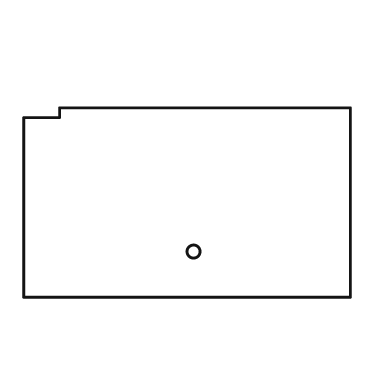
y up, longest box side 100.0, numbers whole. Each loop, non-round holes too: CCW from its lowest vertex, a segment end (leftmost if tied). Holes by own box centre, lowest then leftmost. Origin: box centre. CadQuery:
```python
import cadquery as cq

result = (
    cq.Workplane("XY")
    .moveTo(-50.0, -29.0)
    .lineTo(50.0, -29.0)
    .lineTo(50.0, 29.0)
    .lineTo(-39.0, 29.0)
    .lineTo(-39.0, 26.0)
    .lineTo(-50.0, 26.0)
    .close()
    .moveTo(2.0, -15.0)
    .circle(2.0)
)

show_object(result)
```